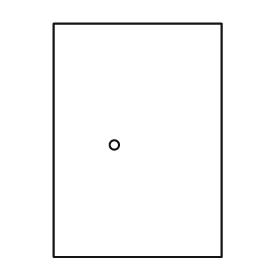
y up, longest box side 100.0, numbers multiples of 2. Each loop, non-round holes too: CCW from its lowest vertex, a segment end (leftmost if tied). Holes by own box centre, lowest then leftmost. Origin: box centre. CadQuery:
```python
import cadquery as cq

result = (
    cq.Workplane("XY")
    .moveTo(-36.0, -50.0)
    .lineTo(36.0, -50.0)
    .lineTo(36.0, 50.0)
    .lineTo(-36.0, 50.0)
    .close()
    .moveTo(-10.0, -2.0)
    .circle(2.0)
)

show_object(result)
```